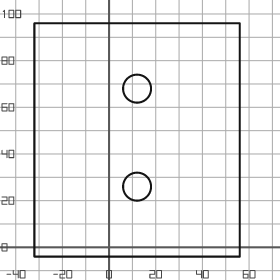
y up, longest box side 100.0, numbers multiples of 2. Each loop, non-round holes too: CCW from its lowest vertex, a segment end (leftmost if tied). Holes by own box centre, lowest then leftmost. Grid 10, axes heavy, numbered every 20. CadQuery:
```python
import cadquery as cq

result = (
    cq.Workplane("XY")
    .moveTo(-32.0, -4.0)
    .lineTo(56.0, -4.0)
    .lineTo(56.0, 96.0)
    .lineTo(-32.0, 96.0)
    .close()
    .moveTo(12.0, 26.0)
    .circle(6.0)
    .moveTo(12.0, 68.0)
    .circle(6.0)
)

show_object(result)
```